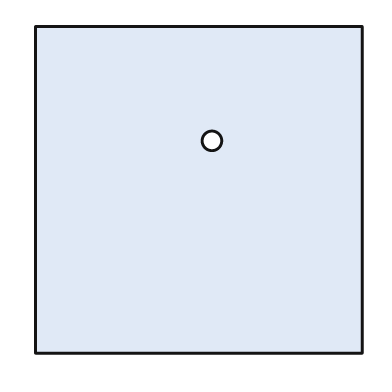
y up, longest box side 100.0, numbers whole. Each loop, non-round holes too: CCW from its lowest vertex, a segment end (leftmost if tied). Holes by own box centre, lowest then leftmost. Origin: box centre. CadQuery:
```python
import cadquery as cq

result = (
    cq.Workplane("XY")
    .moveTo(-50.0, -50.0)
    .lineTo(50.0, -50.0)
    .lineTo(50.0, 50.0)
    .lineTo(-50.0, 50.0)
    .close()
    .moveTo(4.0, 15.0)
    .circle(3.0)
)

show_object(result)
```